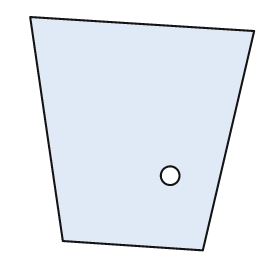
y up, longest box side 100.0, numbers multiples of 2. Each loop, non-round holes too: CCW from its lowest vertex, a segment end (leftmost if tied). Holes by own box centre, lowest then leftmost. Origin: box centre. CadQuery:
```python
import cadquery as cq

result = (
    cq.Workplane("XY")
    .moveTo(26.0, -50.0)
    .lineTo(48.0, 44.0)
    .lineTo(-48.0, 50.0)
    .lineTo(-34.0, -46.0)
    .close()
    .moveTo(12.0, -18.0)
    .circle(4.0)
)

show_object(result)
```